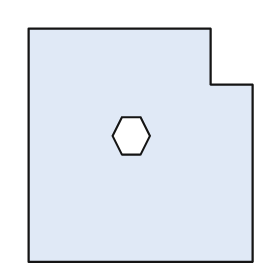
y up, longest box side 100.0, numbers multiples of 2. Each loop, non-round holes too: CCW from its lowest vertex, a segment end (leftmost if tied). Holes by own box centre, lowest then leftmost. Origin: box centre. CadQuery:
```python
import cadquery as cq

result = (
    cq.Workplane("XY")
    .moveTo(-48.0, -50.0)
    .lineTo(48.0, -50.0)
    .lineTo(48.0, 26.0)
    .lineTo(30.0, 26.0)
    .lineTo(30.0, 50.0)
    .lineTo(-48.0, 50.0)
    .close()
    .moveTo(-8.0, -4.0)
    .lineTo(0.0, -4.0)
    .lineTo(4.0, 4.0)
    .lineTo(0.0, 12.0)
    .lineTo(-8.0, 12.0)
    .lineTo(-12.0, 4.0)
    .close()
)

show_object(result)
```